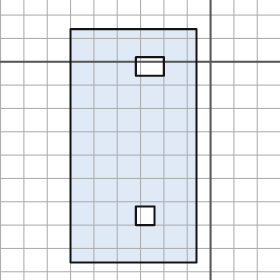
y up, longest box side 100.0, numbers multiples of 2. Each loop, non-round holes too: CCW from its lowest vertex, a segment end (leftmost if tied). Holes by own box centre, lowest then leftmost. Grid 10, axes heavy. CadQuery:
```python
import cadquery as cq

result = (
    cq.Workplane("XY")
    .moveTo(-60.0, -86.0)
    .lineTo(-6.0, -86.0)
    .lineTo(-6.0, 14.0)
    .lineTo(-60.0, 14.0)
    .close()
    .moveTo(-32.0, -70.0)
    .lineTo(-24.0, -70.0)
    .lineTo(-24.0, -62.0)
    .lineTo(-32.0, -62.0)
    .close()
    .moveTo(-32.0, -6.0)
    .lineTo(-20.0, -6.0)
    .lineTo(-20.0, 2.0)
    .lineTo(-32.0, 2.0)
    .close()
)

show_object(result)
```